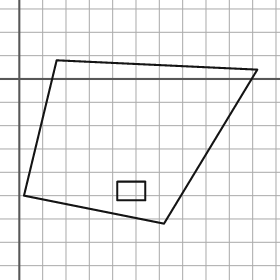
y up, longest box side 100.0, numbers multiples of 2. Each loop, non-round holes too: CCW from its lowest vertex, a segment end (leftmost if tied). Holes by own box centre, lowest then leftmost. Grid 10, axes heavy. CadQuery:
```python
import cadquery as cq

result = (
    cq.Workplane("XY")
    .moveTo(62.0, -62.0)
    .lineTo(102.0, 4.0)
    .lineTo(16.0, 8.0)
    .lineTo(2.0, -50.0)
    .close()
    .moveTo(42.0, -52.0)
    .lineTo(54.0, -52.0)
    .lineTo(54.0, -44.0)
    .lineTo(42.0, -44.0)
    .close()
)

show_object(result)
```